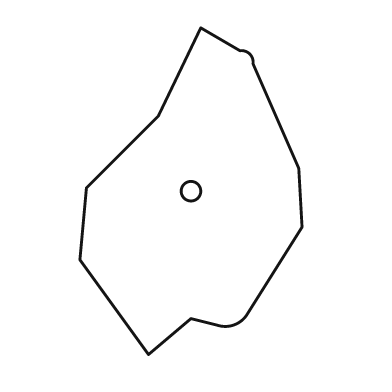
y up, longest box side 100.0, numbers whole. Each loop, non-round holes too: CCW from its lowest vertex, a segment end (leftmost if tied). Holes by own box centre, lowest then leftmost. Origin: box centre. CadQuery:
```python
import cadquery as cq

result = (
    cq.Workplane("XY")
    .moveTo(-13.0, -50.0)
    .lineTo(0.0, -39.0)
    .lineTo(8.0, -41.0)
    .threePointArc((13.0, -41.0), (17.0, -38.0))
    .lineTo(34.0, -11.0)
    .lineTo(33.0, 7.0)
    .lineTo(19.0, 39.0)
    .threePointArc((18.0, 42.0), (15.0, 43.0))
    .lineTo(3.0, 50.0)
    .lineTo(-10.0, 23.0)
    .lineTo(-32.0, 1.0)
    .lineTo(-34.0, -21.0)
    .close()
    .moveTo(0.0, 0.0)
    .circle(3.0)
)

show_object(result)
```